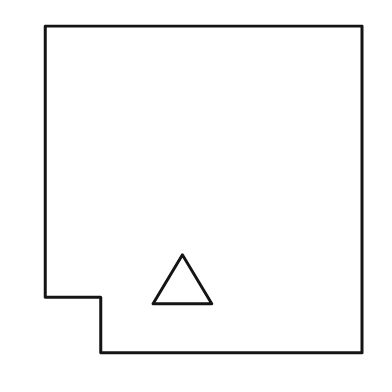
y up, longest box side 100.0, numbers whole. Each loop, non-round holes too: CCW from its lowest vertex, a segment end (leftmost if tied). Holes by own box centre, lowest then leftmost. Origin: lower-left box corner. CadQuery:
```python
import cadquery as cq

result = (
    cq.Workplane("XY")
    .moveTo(17.0, 0.0)
    .lineTo(97.0, 0.0)
    .lineTo(97.0, 100.0)
    .lineTo(0.0, 100.0)
    .lineTo(0.0, 17.0)
    .lineTo(17.0, 17.0)
    .close()
    .moveTo(33.0, 15.0)
    .lineTo(51.0, 15.0)
    .lineTo(42.0, 30.0)
    .close()
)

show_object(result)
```